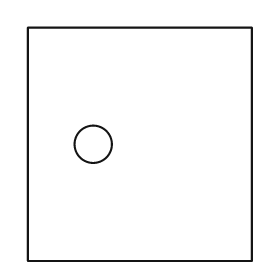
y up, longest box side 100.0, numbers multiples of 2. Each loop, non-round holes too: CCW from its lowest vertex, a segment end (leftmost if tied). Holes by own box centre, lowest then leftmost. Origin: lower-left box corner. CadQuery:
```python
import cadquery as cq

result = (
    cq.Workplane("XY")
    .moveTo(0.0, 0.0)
    .lineTo(96.0, 0.0)
    .lineTo(96.0, 100.0)
    .lineTo(0.0, 100.0)
    .close()
    .moveTo(28.0, 50.0)
    .circle(8.0)
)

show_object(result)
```